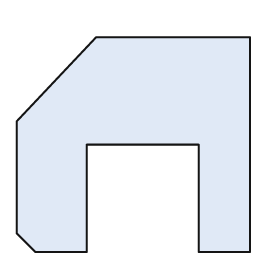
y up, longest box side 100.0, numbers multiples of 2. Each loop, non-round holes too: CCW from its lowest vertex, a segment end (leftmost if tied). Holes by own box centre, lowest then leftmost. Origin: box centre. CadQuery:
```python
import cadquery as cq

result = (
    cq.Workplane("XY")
    .moveTo(-42.0, -46.0)
    .lineTo(-20.0, -46.0)
    .lineTo(-20.0, 0.0)
    .lineTo(28.0, 0.0)
    .lineTo(28.0, -46.0)
    .lineTo(50.0, -46.0)
    .lineTo(50.0, 46.0)
    .lineTo(-16.0, 46.0)
    .lineTo(-50.0, 10.0)
    .lineTo(-50.0, -38.0)
    .close()
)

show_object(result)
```